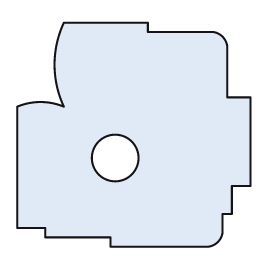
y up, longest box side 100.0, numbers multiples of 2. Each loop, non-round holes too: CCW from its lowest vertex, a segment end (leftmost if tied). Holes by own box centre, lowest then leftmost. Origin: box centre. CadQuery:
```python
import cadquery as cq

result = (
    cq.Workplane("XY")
    .moveTo(-10.0, -48.0)
    .lineTo(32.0, -48.0)
    .threePointArc((36.0, -46.0), (38.0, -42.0))
    .lineTo(38.0, -34.0)
    .lineTo(42.0, -34.0)
    .lineTo(42.0, -22.0)
    .lineTo(50.0, -22.0)
    .lineTo(50.0, 16.0)
    .lineTo(40.0, 16.0)
    .lineTo(40.0, 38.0)
    .threePointArc((38.0, 42.0), (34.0, 44.0))
    .lineTo(6.0, 44.0)
    .lineTo(6.0, 48.0)
    .lineTo(-30.0, 48.0)
    .threePointArc((-34.0, 30.0), (-30.0, 12.0))
    .threePointArc((-40.0, 14.0), (-50.0, 12.0))
    .lineTo(-50.0, -40.0)
    .lineTo(-38.0, -40.0)
    .lineTo(-38.0, -44.0)
    .lineTo(-10.0, -44.0)
    .close()
    .moveTo(-8.0, -10.0)
    .circle(10.0)
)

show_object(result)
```